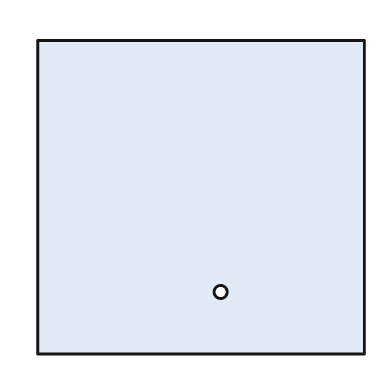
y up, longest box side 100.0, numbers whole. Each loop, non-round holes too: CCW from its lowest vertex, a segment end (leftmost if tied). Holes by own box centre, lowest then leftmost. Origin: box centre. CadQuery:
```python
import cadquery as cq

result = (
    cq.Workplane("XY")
    .moveTo(-50.0, -48.0)
    .lineTo(50.0, -48.0)
    .lineTo(50.0, 48.0)
    .lineTo(-50.0, 48.0)
    .close()
    .moveTo(6.0, -29.0)
    .circle(2.0)
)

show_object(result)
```